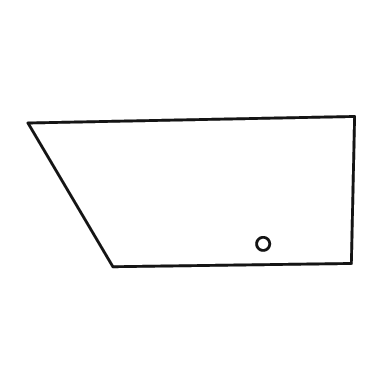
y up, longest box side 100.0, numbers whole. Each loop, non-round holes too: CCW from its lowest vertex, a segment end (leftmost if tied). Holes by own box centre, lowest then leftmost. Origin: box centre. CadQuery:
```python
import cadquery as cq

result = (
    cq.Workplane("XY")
    .moveTo(-24.0, -23.0)
    .lineTo(49.0, -22.0)
    .lineTo(50.0, 23.0)
    .lineTo(-50.0, 21.0)
    .close()
    .moveTo(22.0, -16.0)
    .circle(2.0)
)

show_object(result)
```